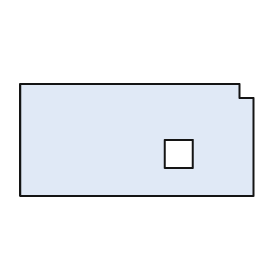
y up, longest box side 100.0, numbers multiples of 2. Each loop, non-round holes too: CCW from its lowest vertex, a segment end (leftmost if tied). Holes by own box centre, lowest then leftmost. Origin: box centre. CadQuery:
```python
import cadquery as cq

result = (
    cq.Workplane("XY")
    .moveTo(-50.0, -24.0)
    .lineTo(50.0, -24.0)
    .lineTo(50.0, 18.0)
    .lineTo(44.0, 18.0)
    .lineTo(44.0, 24.0)
    .lineTo(-50.0, 24.0)
    .close()
    .moveTo(12.0, -12.0)
    .lineTo(24.0, -12.0)
    .lineTo(24.0, 0.0)
    .lineTo(12.0, 0.0)
    .close()
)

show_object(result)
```